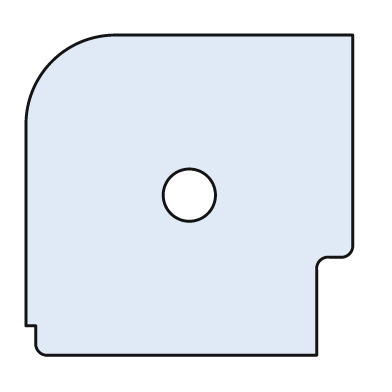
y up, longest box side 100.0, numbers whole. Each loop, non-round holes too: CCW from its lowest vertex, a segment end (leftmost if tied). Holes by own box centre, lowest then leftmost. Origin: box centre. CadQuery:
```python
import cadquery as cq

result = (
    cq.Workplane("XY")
    .moveTo(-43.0, -49.0)
    .lineTo(39.0, -49.0)
    .lineTo(39.0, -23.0)
    .threePointArc((40.0, -20.0), (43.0, -19.0))
    .lineTo(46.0, -19.0)
    .threePointArc((49.0, -18.0), (50.0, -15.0))
    .lineTo(50.0, 49.0)
    .lineTo(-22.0, 49.0)
    .threePointArc((-42.0, 41.0), (-50.0, 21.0))
    .lineTo(-50.0, -40.0)
    .lineTo(-47.0, -40.0)
    .lineTo(-47.0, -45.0)
    .threePointArc((-46.0, -48.0), (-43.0, -49.0))
    .close()
    .moveTo(0.0, 0.0)
    .circle(8.0)
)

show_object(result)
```